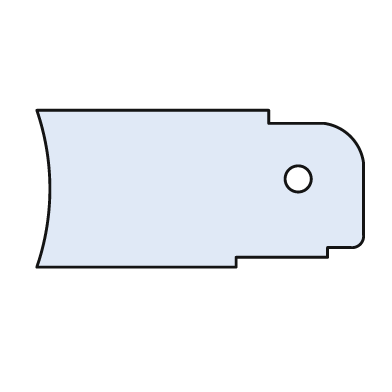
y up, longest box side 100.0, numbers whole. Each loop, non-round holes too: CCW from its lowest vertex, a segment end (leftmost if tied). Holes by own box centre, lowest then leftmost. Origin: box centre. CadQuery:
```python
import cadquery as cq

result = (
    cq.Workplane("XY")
    .moveTo(-50.0, -24.0)
    .lineTo(11.0, -24.0)
    .lineTo(11.0, -21.0)
    .lineTo(39.0, -21.0)
    .lineTo(39.0, -18.0)
    .lineTo(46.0, -18.0)
    .threePointArc((49.0, -17.0), (50.0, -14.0))
    .lineTo(50.0, 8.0)
    .threePointArc((46.0, 16.0), (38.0, 20.0))
    .lineTo(21.0, 20.0)
    .lineTo(21.0, 24.0)
    .lineTo(-50.0, 24.0)
    .threePointArc((-46.0, 0.0), (-50.0, -24.0))
    .close()
    .moveTo(30.0, 3.0)
    .circle(4.0)
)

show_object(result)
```